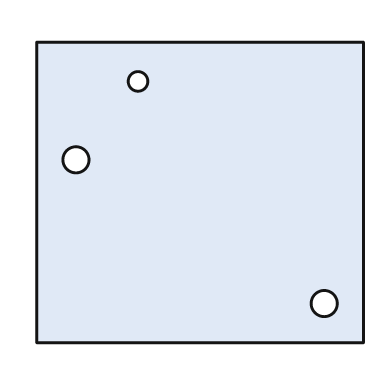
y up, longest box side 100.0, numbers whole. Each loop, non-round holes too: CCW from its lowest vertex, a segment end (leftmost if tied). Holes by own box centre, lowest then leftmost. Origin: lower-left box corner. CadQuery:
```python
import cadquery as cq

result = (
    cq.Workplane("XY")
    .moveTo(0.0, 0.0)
    .lineTo(100.0, 0.0)
    .lineTo(100.0, 92.0)
    .lineTo(0.0, 92.0)
    .close()
    .moveTo(88.0, 12.0)
    .circle(4.0)
    .moveTo(12.0, 56.0)
    .circle(4.0)
    .moveTo(31.0, 80.0)
    .circle(3.0)
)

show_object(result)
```